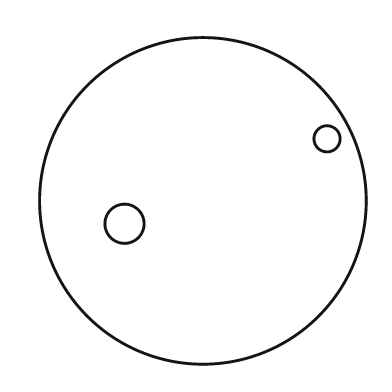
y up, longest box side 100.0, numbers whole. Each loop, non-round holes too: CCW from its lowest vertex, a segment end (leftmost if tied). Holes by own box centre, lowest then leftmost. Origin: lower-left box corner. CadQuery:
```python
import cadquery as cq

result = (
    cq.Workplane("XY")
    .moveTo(50.0, 50.0)
    .circle(50.0)
    .moveTo(26.0, 43.0)
    .circle(6.0)
    .moveTo(88.0, 69.0)
    .circle(4.0)
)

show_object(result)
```